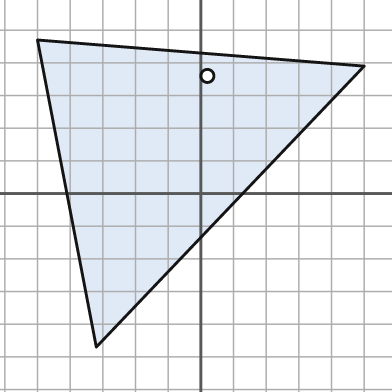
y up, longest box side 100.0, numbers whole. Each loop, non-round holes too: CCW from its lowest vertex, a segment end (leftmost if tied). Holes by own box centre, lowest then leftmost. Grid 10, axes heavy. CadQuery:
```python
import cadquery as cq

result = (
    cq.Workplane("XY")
    .moveTo(-32.0, -47.0)
    .lineTo(50.0, 39.0)
    .lineTo(-50.0, 47.0)
    .close()
    .moveTo(2.0, 36.0)
    .circle(2.0)
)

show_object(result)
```